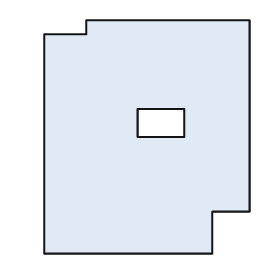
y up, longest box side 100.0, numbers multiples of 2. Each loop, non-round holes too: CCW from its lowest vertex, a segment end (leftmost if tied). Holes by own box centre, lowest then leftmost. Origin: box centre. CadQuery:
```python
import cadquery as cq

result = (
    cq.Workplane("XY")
    .moveTo(-44.0, -50.0)
    .lineTo(28.0, -50.0)
    .lineTo(28.0, -32.0)
    .lineTo(44.0, -32.0)
    .lineTo(44.0, 50.0)
    .lineTo(-26.0, 50.0)
    .lineTo(-26.0, 44.0)
    .lineTo(-44.0, 44.0)
    .close()
    .moveTo(-4.0, 0.0)
    .lineTo(16.0, 0.0)
    .lineTo(16.0, 12.0)
    .lineTo(-4.0, 12.0)
    .close()
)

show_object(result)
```